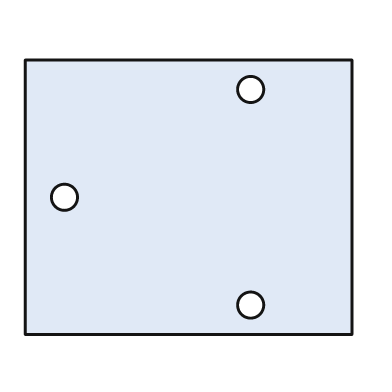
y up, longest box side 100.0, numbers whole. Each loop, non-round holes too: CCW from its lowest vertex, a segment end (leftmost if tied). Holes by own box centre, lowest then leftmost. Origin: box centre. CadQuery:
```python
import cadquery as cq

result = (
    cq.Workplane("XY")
    .moveTo(-50.0, -42.0)
    .lineTo(50.0, -42.0)
    .lineTo(50.0, 42.0)
    .lineTo(-50.0, 42.0)
    .close()
    .moveTo(19.0, -33.0)
    .circle(4.0)
    .moveTo(-38.0, 0.0)
    .circle(4.0)
    .moveTo(19.0, 33.0)
    .circle(4.0)
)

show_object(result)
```